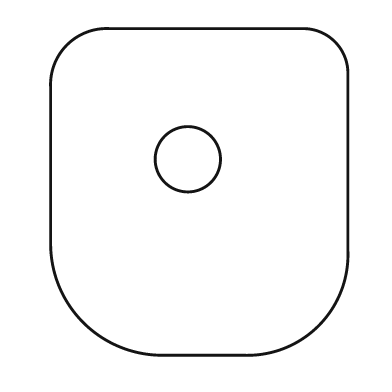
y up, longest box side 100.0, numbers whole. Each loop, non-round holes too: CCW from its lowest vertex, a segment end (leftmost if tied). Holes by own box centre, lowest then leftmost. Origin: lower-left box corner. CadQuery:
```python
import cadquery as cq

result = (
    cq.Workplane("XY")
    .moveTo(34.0, 0.0)
    .lineTo(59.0, 0.0)
    .threePointArc((82.0, 9.0), (91.0, 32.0))
    .lineTo(91.0, 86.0)
    .threePointArc((87.0, 96.0), (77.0, 100.0))
    .lineTo(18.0, 100.0)
    .threePointArc((5.0, 95.0), (0.0, 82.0))
    .lineTo(0.0, 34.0)
    .threePointArc((10.0, 10.0), (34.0, 0.0))
    .close()
    .moveTo(42.0, 60.0)
    .circle(10.0)
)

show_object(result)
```